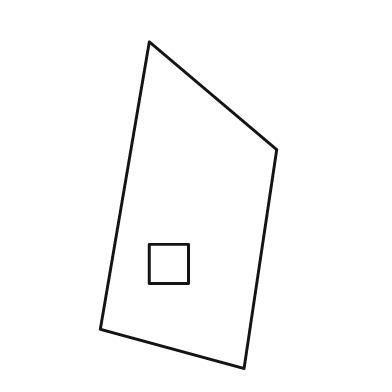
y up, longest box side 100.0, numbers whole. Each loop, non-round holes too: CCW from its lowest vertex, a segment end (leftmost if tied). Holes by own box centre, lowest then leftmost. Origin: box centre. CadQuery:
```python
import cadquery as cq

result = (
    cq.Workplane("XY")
    .moveTo(17.0, -50.0)
    .lineTo(27.0, 17.0)
    .lineTo(-12.0, 50.0)
    .lineTo(-27.0, -38.0)
    .close()
    .moveTo(-12.0, -24.0)
    .lineTo(0.0, -24.0)
    .lineTo(0.0, -12.0)
    .lineTo(-12.0, -12.0)
    .close()
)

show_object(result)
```